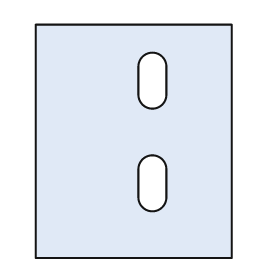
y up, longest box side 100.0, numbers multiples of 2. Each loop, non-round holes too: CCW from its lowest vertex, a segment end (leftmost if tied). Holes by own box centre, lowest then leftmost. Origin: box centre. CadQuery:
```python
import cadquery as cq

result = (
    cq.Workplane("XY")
    .moveTo(-42.0, -50.0)
    .lineTo(42.0, -50.0)
    .lineTo(42.0, 50.0)
    .lineTo(-42.0, 50.0)
    .close()
    .moveTo(2.0, -24.0)
    .threePointArc((8.0, -30.0), (14.0, -24.0))
    .lineTo(14.0, -12.0)
    .threePointArc((8.0, -6.0), (2.0, -12.0))
    .close()
    .moveTo(2.0, 20.0)
    .threePointArc((8.0, 14.0), (14.0, 20.0))
    .lineTo(14.0, 32.0)
    .threePointArc((8.0, 38.0), (2.0, 32.0))
    .close()
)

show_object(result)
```